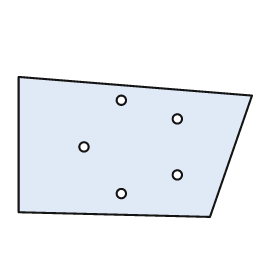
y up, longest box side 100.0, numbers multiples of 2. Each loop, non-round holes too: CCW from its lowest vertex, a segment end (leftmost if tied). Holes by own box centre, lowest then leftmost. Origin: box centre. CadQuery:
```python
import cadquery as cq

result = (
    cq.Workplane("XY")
    .moveTo(32.0, -30.0)
    .lineTo(50.0, 22.0)
    .lineTo(-50.0, 30.0)
    .lineTo(-50.0, -28.0)
    .close()
    .moveTo(-6.0, -20.0)
    .circle(2.0)
    .moveTo(18.0, -12.0)
    .circle(2.0)
    .moveTo(-22.0, 0.0)
    .circle(2.0)
    .moveTo(18.0, 12.0)
    .circle(2.0)
    .moveTo(-6.0, 20.0)
    .circle(2.0)
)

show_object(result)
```